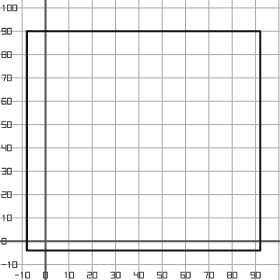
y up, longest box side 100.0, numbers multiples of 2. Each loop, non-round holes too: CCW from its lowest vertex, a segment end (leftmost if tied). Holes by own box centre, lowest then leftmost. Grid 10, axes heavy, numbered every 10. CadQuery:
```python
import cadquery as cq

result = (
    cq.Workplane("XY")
    .moveTo(-8.0, -4.0)
    .lineTo(92.0, -4.0)
    .lineTo(92.0, 90.0)
    .lineTo(-8.0, 90.0)
    .close()
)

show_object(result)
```